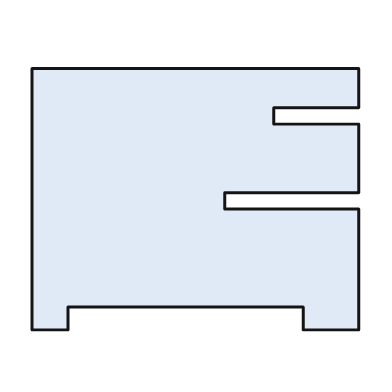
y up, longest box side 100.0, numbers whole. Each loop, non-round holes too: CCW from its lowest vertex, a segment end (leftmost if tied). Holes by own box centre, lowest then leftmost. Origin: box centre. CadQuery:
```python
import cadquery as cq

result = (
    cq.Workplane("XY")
    .moveTo(-50.0, -40.0)
    .lineTo(-39.0, -40.0)
    .lineTo(-39.0, -33.0)
    .lineTo(33.0, -33.0)
    .lineTo(33.0, -40.0)
    .lineTo(50.0, -40.0)
    .lineTo(50.0, -3.0)
    .lineTo(9.0, -3.0)
    .lineTo(9.0, 2.0)
    .lineTo(50.0, 2.0)
    .lineTo(50.0, 23.0)
    .lineTo(24.0, 23.0)
    .lineTo(24.0, 28.0)
    .lineTo(50.0, 28.0)
    .lineTo(50.0, 40.0)
    .lineTo(-50.0, 40.0)
    .close()
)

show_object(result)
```